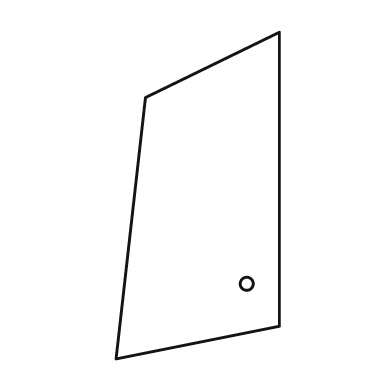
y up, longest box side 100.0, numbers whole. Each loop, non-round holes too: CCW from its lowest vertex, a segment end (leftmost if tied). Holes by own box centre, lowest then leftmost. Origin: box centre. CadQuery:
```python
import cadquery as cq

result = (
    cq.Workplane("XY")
    .moveTo(-25.0, -50.0)
    .lineTo(25.0, -40.0)
    .lineTo(25.0, 50.0)
    .lineTo(-16.0, 30.0)
    .close()
    .moveTo(15.0, -27.0)
    .circle(2.0)
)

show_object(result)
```